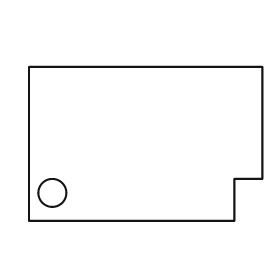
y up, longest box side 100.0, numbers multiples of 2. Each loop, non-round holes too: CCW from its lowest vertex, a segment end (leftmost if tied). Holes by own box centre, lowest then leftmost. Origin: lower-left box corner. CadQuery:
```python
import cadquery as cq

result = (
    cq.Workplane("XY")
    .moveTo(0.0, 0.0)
    .lineTo(88.0, 0.0)
    .lineTo(88.0, 18.0)
    .lineTo(100.0, 18.0)
    .lineTo(100.0, 66.0)
    .lineTo(0.0, 66.0)
    .close()
    .moveTo(10.0, 12.0)
    .circle(6.0)
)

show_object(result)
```